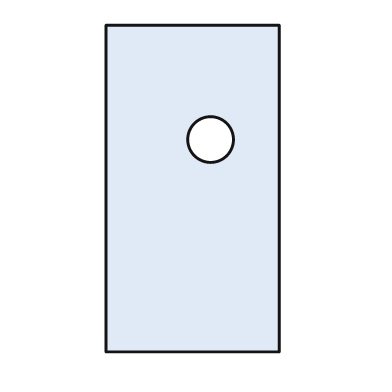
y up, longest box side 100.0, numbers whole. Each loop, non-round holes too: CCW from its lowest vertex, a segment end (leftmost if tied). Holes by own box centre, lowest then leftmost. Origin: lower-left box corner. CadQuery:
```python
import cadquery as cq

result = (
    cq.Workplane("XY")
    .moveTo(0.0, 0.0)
    .lineTo(53.0, 0.0)
    .lineTo(53.0, 100.0)
    .lineTo(0.0, 100.0)
    .close()
    .moveTo(32.0, 65.0)
    .circle(7.0)
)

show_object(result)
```